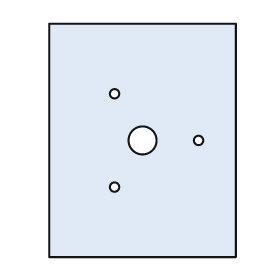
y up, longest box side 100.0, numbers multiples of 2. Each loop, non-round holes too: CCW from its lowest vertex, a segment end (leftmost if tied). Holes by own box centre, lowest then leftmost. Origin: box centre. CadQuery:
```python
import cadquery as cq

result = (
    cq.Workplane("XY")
    .moveTo(-40.0, -50.0)
    .lineTo(40.0, -50.0)
    .lineTo(40.0, 50.0)
    .lineTo(-40.0, 50.0)
    .close()
    .moveTo(-12.0, -20.0)
    .circle(2.0)
    .moveTo(0.0, 0.0)
    .circle(6.0)
    .moveTo(24.0, 0.0)
    .circle(2.0)
    .moveTo(-12.0, 20.0)
    .circle(2.0)
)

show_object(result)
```